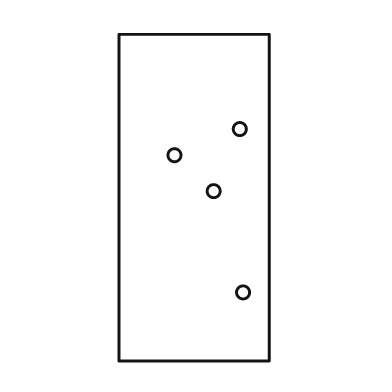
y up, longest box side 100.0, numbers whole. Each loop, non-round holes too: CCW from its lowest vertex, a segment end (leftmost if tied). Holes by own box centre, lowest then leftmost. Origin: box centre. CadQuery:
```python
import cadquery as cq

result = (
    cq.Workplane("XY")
    .moveTo(-23.0, -50.0)
    .lineTo(23.0, -50.0)
    .lineTo(23.0, 50.0)
    .lineTo(-23.0, 50.0)
    .close()
    .moveTo(15.0, -29.0)
    .circle(2.0)
    .moveTo(6.0, 2.0)
    .circle(2.0)
    .moveTo(-6.0, 13.0)
    .circle(2.0)
    .moveTo(14.0, 21.0)
    .circle(2.0)
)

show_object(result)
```